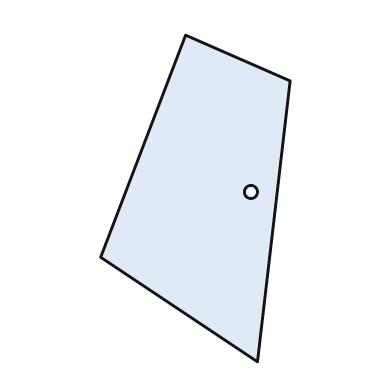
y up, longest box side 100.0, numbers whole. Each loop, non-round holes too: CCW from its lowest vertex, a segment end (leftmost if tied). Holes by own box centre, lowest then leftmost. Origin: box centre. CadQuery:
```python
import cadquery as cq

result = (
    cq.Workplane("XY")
    .moveTo(19.0, -50.0)
    .lineTo(29.0, 36.0)
    .lineTo(-3.0, 50.0)
    .lineTo(-29.0, -18.0)
    .close()
    .moveTo(17.0, 2.0)
    .circle(2.0)
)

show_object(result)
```